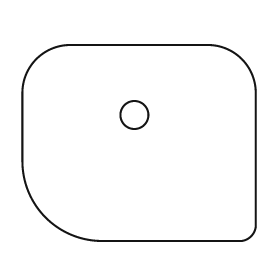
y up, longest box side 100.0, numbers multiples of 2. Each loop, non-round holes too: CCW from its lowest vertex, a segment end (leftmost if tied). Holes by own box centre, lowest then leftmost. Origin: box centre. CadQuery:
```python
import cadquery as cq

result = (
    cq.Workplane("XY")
    .moveTo(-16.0, -42.0)
    .lineTo(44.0, -42.0)
    .threePointArc((48.0, -40.0), (50.0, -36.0))
    .lineTo(50.0, 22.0)
    .threePointArc((44.0, 36.0), (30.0, 42.0))
    .lineTo(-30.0, 42.0)
    .threePointArc((-44.0, 36.0), (-50.0, 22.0))
    .lineTo(-50.0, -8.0)
    .threePointArc((-40.0, -32.0), (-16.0, -42.0))
    .close()
    .moveTo(-2.0, 12.0)
    .circle(6.0)
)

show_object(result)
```